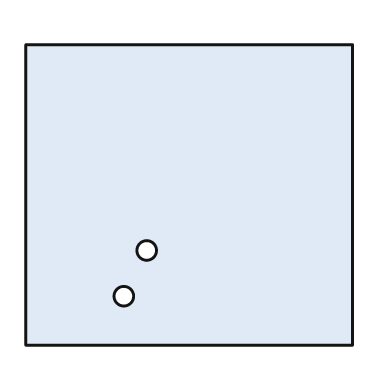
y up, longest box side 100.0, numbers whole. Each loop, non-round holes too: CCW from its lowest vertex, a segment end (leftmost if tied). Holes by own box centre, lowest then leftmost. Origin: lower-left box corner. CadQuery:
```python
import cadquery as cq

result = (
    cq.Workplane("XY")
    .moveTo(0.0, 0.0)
    .lineTo(100.0, 0.0)
    .lineTo(100.0, 92.0)
    .lineTo(0.0, 92.0)
    .close()
    .moveTo(30.0, 15.0)
    .circle(3.0)
    .moveTo(37.0, 29.0)
    .circle(3.0)
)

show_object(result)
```